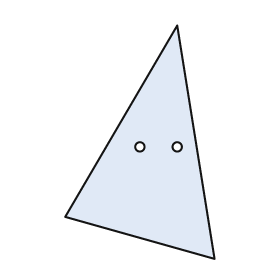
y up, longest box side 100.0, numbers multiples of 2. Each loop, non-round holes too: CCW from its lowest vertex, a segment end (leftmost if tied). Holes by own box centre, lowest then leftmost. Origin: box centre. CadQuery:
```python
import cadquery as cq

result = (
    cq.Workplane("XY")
    .moveTo(32.0, -50.0)
    .lineTo(16.0, 50.0)
    .lineTo(-32.0, -32.0)
    .close()
    .moveTo(0.0, -2.0)
    .circle(2.0)
    .moveTo(16.0, -2.0)
    .circle(2.0)
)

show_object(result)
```